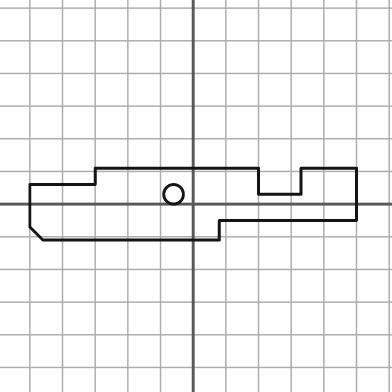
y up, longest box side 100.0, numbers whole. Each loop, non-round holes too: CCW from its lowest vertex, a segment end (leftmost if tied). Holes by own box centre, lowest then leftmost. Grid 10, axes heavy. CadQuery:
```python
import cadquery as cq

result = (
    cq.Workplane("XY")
    .moveTo(-46.0, -11.0)
    .lineTo(8.0, -11.0)
    .lineTo(8.0, -5.0)
    .lineTo(50.0, -5.0)
    .lineTo(50.0, 11.0)
    .lineTo(33.0, 11.0)
    .lineTo(33.0, 3.0)
    .lineTo(20.0, 3.0)
    .lineTo(20.0, 11.0)
    .lineTo(-30.0, 11.0)
    .lineTo(-30.0, 6.0)
    .lineTo(-50.0, 6.0)
    .lineTo(-50.0, -7.0)
    .close()
    .moveTo(-6.0, 3.0)
    .circle(3.0)
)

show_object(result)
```